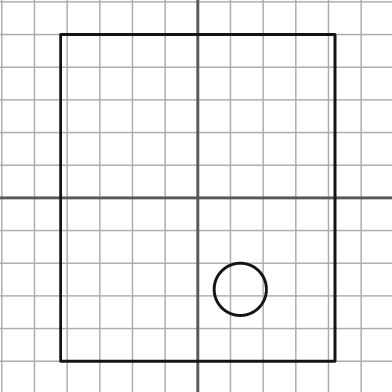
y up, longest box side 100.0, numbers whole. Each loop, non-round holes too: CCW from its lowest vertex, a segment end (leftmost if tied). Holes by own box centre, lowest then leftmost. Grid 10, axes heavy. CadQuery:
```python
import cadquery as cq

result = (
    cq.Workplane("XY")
    .moveTo(-42.0, -50.0)
    .lineTo(42.0, -50.0)
    .lineTo(42.0, 50.0)
    .lineTo(-42.0, 50.0)
    .close()
    .moveTo(13.0, -28.0)
    .circle(8.0)
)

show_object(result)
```